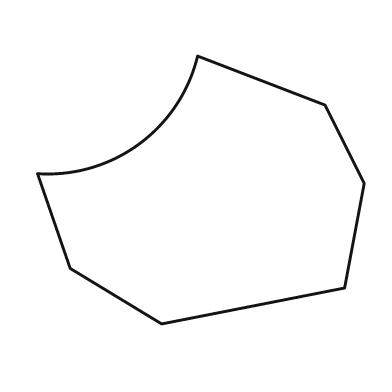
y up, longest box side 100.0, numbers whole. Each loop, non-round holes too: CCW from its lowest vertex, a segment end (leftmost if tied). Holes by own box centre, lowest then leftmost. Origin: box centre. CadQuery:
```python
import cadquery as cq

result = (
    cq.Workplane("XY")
    .moveTo(-12.0, -41.0)
    .lineTo(44.0, -30.0)
    .lineTo(50.0, 2.0)
    .lineTo(38.0, 26.0)
    .lineTo(-1.0, 41.0)
    .threePointArc((-19.0, 14.0), (-50.0, 5.0))
    .lineTo(-40.0, -24.0)
    .close()
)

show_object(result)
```